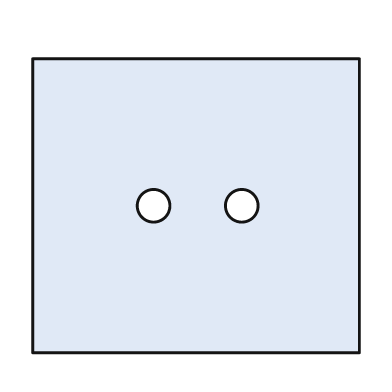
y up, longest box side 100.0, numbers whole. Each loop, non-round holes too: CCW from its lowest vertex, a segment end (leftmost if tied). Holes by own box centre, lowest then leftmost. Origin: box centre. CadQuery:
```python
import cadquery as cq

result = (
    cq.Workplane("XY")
    .moveTo(-50.0, -45.0)
    .lineTo(50.0, -45.0)
    .lineTo(50.0, 45.0)
    .lineTo(-50.0, 45.0)
    .close()
    .moveTo(-13.0, 0.0)
    .circle(5.0)
    .moveTo(14.0, 0.0)
    .circle(5.0)
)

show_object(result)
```